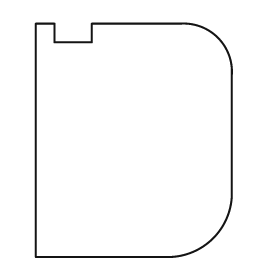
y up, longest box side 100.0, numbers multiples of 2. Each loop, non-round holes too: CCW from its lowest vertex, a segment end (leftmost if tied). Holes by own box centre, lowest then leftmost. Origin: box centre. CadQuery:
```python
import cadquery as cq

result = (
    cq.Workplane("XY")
    .moveTo(-42.0, -50.0)
    .lineTo(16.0, -50.0)
    .threePointArc((34.0, -42.0), (42.0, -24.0))
    .lineTo(42.0, 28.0)
    .threePointArc((36.0, 44.0), (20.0, 50.0))
    .lineTo(-18.0, 50.0)
    .lineTo(-18.0, 42.0)
    .lineTo(-34.0, 42.0)
    .lineTo(-34.0, 50.0)
    .lineTo(-42.0, 50.0)
    .close()
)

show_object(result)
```